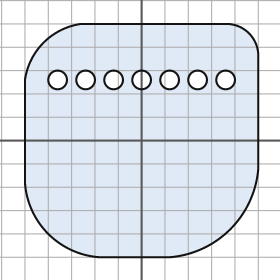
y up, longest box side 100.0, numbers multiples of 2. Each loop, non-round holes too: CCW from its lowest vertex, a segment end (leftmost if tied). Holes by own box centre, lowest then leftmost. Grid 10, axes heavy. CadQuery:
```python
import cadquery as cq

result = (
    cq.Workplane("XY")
    .moveTo(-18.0, -50.0)
    .lineTo(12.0, -50.0)
    .threePointArc((38.0, -38.0), (50.0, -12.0))
    .lineTo(50.0, 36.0)
    .threePointArc((46.0, 46.0), (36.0, 50.0))
    .lineTo(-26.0, 50.0)
    .threePointArc((-42.0, 42.0), (-50.0, 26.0))
    .lineTo(-50.0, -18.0)
    .threePointArc((-40.0, -40.0), (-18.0, -50.0))
    .close()
    .moveTo(-36.0, 26.0)
    .circle(4.0)
    .moveTo(-24.0, 26.0)
    .circle(4.0)
    .moveTo(-12.0, 26.0)
    .circle(4.0)
    .moveTo(0.0, 26.0)
    .circle(4.0)
    .moveTo(12.0, 26.0)
    .circle(4.0)
    .moveTo(24.0, 26.0)
    .circle(4.0)
    .moveTo(36.0, 26.0)
    .circle(4.0)
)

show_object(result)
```